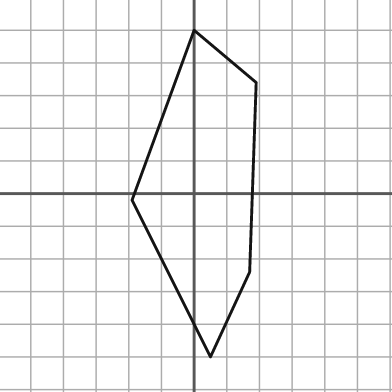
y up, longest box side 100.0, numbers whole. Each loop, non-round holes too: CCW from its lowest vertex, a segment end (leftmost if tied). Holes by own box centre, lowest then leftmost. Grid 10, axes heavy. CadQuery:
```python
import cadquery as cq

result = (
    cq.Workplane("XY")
    .moveTo(5.0, -50.0)
    .lineTo(17.0, -24.0)
    .lineTo(19.0, 34.0)
    .lineTo(0.0, 50.0)
    .lineTo(-19.0, -2.0)
    .close()
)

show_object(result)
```